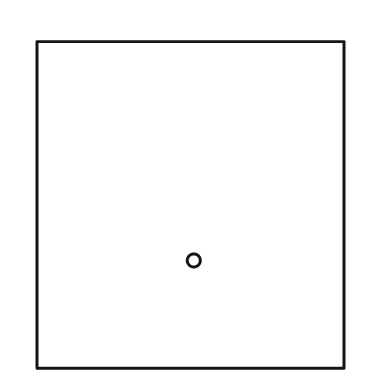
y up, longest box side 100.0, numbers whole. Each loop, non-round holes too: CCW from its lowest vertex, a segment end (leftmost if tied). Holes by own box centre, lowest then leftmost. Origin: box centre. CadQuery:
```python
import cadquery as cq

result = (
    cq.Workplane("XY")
    .moveTo(-47.0, -50.0)
    .lineTo(47.0, -50.0)
    .lineTo(47.0, 50.0)
    .lineTo(-47.0, 50.0)
    .close()
    .moveTo(1.0, -17.0)
    .circle(2.0)
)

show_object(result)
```